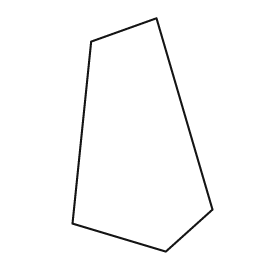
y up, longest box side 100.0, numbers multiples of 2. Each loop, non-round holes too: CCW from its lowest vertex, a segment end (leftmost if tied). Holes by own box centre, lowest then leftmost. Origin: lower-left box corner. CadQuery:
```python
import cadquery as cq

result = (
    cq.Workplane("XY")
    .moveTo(40.0, 0.0)
    .lineTo(60.0, 18.0)
    .lineTo(36.0, 100.0)
    .lineTo(8.0, 90.0)
    .lineTo(0.0, 12.0)
    .close()
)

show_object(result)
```